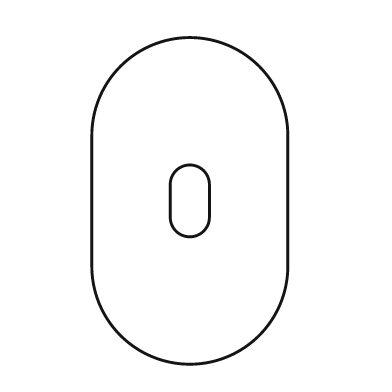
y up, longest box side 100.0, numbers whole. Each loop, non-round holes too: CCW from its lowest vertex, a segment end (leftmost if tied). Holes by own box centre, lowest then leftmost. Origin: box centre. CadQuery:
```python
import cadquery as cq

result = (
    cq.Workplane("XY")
    .moveTo(-30.0, -20.0)
    .threePointArc((0.0, -50.0), (30.0, -20.0))
    .lineTo(30.0, 20.0)
    .threePointArc((0.0, 50.0), (-30.0, 20.0))
    .close()
    .moveTo(-6.0, -5.0)
    .threePointArc((0.0, -11.0), (6.0, -5.0))
    .lineTo(6.0, 5.0)
    .threePointArc((0.0, 11.0), (-6.0, 5.0))
    .close()
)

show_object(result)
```